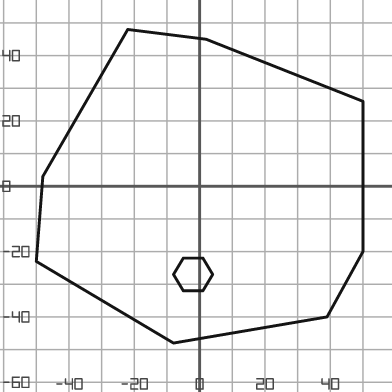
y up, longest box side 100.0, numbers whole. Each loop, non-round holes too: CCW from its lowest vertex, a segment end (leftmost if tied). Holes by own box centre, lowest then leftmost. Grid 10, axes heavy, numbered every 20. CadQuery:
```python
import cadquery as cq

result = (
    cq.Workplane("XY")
    .moveTo(-8.0, -48.0)
    .lineTo(39.0, -40.0)
    .lineTo(50.0, -20.0)
    .lineTo(50.0, 26.0)
    .lineTo(2.0, 45.0)
    .lineTo(-22.0, 48.0)
    .lineTo(-48.0, 3.0)
    .lineTo(-50.0, -23.0)
    .close()
    .moveTo(-5.0, -32.0)
    .lineTo(1.0, -32.0)
    .lineTo(4.0, -27.0)
    .lineTo(1.0, -22.0)
    .lineTo(-5.0, -22.0)
    .lineTo(-8.0, -27.0)
    .close()
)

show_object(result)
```